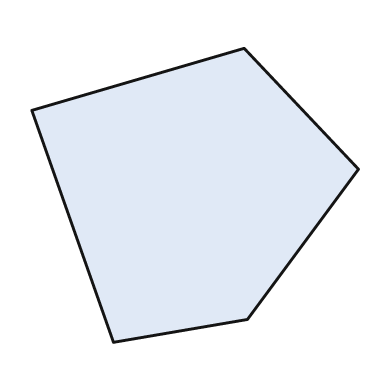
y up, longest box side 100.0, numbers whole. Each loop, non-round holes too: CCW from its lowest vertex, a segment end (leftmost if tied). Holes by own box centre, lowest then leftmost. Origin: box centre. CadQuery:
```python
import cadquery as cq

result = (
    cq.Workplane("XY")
    .moveTo(-25.0, -45.0)
    .lineTo(16.0, -38.0)
    .lineTo(50.0, 8.0)
    .lineTo(15.0, 45.0)
    .lineTo(-50.0, 26.0)
    .close()
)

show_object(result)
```